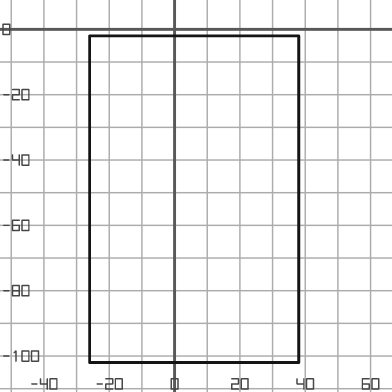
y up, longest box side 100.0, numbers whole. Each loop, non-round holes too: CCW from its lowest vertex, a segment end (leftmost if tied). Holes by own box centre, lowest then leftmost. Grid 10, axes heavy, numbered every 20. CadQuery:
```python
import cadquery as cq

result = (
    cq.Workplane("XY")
    .moveTo(-26.0, -102.0)
    .lineTo(38.0, -102.0)
    .lineTo(38.0, -2.0)
    .lineTo(-26.0, -2.0)
    .close()
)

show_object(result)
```